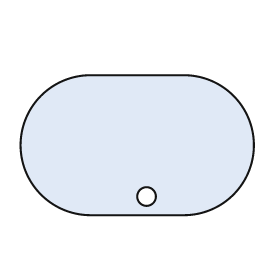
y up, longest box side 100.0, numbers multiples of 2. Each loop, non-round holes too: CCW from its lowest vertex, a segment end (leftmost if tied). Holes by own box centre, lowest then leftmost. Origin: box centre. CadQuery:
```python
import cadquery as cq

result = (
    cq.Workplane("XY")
    .moveTo(-20.0, -30.0)
    .lineTo(20.0, -30.0)
    .threePointArc((50.0, 0.0), (20.0, 30.0))
    .lineTo(-20.0, 30.0)
    .threePointArc((-50.0, 0.0), (-20.0, -30.0))
    .close()
    .moveTo(4.0, -22.0)
    .circle(4.0)
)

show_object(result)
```